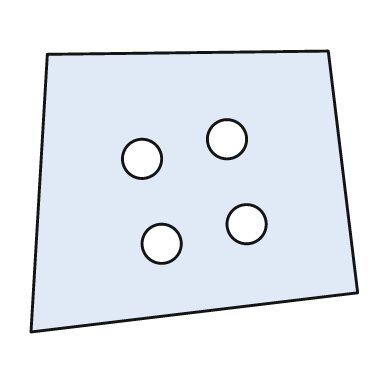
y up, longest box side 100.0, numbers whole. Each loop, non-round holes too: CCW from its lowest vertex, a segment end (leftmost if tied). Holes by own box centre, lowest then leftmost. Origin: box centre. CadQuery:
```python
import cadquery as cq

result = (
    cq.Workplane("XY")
    .moveTo(-50.0, -43.0)
    .lineTo(50.0, -31.0)
    .lineTo(41.0, 43.0)
    .lineTo(-45.0, 42.0)
    .close()
    .moveTo(-10.0, -16.0)
    .circle(6.0)
    .moveTo(16.0, -10.0)
    .circle(6.0)
    .moveTo(-16.0, 10.0)
    .circle(6.0)
    .moveTo(10.0, 16.0)
    .circle(6.0)
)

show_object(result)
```